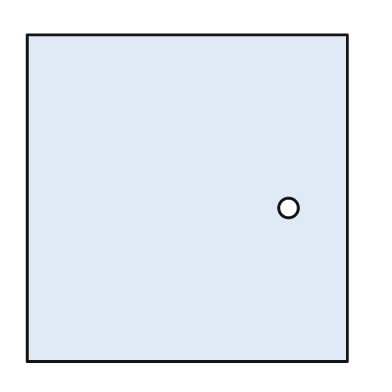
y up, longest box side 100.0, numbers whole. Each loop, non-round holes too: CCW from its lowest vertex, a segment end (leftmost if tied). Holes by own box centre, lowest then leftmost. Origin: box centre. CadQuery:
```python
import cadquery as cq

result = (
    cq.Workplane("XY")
    .moveTo(-49.0, -50.0)
    .lineTo(49.0, -50.0)
    .lineTo(49.0, 50.0)
    .lineTo(-49.0, 50.0)
    .close()
    .moveTo(31.0, -3.0)
    .circle(3.0)
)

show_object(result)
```